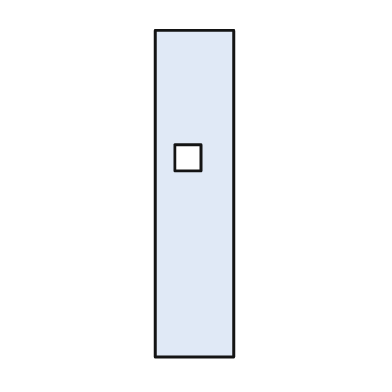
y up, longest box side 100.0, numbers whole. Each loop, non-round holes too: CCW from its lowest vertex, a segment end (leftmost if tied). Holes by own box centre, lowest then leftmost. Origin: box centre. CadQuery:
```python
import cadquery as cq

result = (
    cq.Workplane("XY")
    .moveTo(-12.0, -50.0)
    .lineTo(12.0, -50.0)
    .lineTo(12.0, 50.0)
    .lineTo(-12.0, 50.0)
    .close()
    .moveTo(-6.0, 7.0)
    .lineTo(2.0, 7.0)
    .lineTo(2.0, 15.0)
    .lineTo(-6.0, 15.0)
    .close()
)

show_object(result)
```